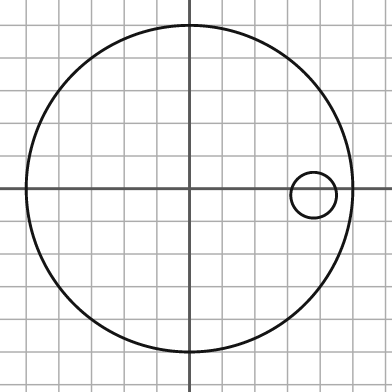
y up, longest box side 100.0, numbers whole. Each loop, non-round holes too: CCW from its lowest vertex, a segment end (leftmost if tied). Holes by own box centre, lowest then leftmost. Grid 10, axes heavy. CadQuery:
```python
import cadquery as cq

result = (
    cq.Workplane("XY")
    .moveTo(0.0, 0.0)
    .circle(50.0)
    .moveTo(38.0, -2.0)
    .circle(7.0)
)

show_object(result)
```